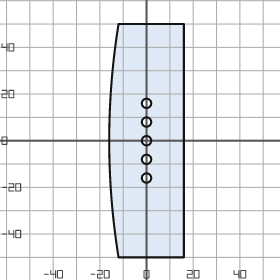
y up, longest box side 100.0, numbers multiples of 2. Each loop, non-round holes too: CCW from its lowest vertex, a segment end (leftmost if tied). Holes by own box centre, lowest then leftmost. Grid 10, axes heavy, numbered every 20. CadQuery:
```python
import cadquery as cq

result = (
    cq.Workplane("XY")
    .moveTo(-12.0, -50.0)
    .lineTo(16.0, -50.0)
    .lineTo(16.0, 50.0)
    .lineTo(-12.0, 50.0)
    .threePointArc((-16.0, 0.0), (-12.0, -50.0))
    .close()
    .moveTo(0.0, -16.0)
    .circle(2.0)
    .moveTo(0.0, -8.0)
    .circle(2.0)
    .moveTo(0.0, 0.0)
    .circle(2.0)
    .moveTo(0.0, 8.0)
    .circle(2.0)
    .moveTo(0.0, 16.0)
    .circle(2.0)
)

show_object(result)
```